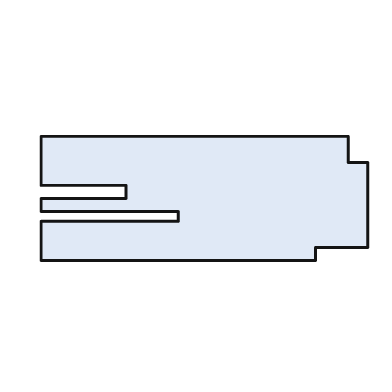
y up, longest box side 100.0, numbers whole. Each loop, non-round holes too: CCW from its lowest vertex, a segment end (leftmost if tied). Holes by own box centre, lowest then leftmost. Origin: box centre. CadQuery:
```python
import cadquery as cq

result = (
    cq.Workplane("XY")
    .moveTo(-50.0, -19.0)
    .lineTo(34.0, -19.0)
    .lineTo(34.0, -15.0)
    .lineTo(50.0, -15.0)
    .lineTo(50.0, 11.0)
    .lineTo(44.0, 11.0)
    .lineTo(44.0, 19.0)
    .lineTo(-50.0, 19.0)
    .lineTo(-50.0, 4.0)
    .lineTo(-24.0, 4.0)
    .lineTo(-24.0, 0.0)
    .lineTo(-50.0, 0.0)
    .lineTo(-50.0, -4.0)
    .lineTo(-8.0, -4.0)
    .lineTo(-8.0, -7.0)
    .lineTo(-50.0, -7.0)
    .close()
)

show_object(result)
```